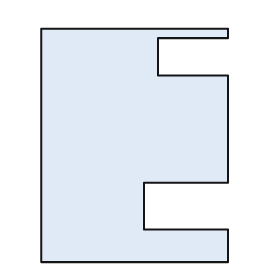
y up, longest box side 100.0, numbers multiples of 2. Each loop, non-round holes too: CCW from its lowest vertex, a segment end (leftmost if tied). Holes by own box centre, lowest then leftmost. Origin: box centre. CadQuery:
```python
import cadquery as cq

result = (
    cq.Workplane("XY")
    .moveTo(-40.0, -50.0)
    .lineTo(40.0, -50.0)
    .lineTo(40.0, -36.0)
    .lineTo(4.0, -36.0)
    .lineTo(4.0, -16.0)
    .lineTo(40.0, -16.0)
    .lineTo(40.0, 30.0)
    .lineTo(10.0, 30.0)
    .lineTo(10.0, 46.0)
    .lineTo(40.0, 46.0)
    .lineTo(40.0, 50.0)
    .lineTo(-40.0, 50.0)
    .close()
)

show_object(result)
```